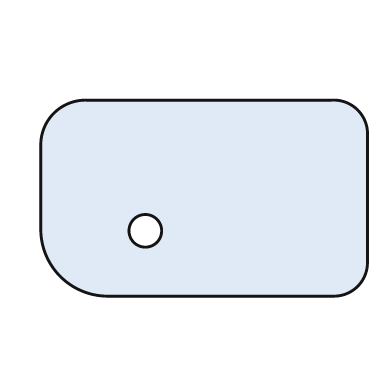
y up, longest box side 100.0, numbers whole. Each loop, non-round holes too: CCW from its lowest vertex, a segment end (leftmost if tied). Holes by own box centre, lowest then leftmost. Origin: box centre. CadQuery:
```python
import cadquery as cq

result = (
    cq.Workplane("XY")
    .moveTo(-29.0, -30.0)
    .lineTo(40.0, -30.0)
    .threePointArc((47.0, -27.0), (50.0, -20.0))
    .lineTo(50.0, 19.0)
    .threePointArc((47.0, 27.0), (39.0, 30.0))
    .lineTo(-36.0, 30.0)
    .threePointArc((-46.0, 26.0), (-50.0, 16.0))
    .lineTo(-50.0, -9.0)
    .threePointArc((-44.0, -24.0), (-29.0, -30.0))
    .close()
    .moveTo(-18.0, -10.0)
    .circle(5.0)
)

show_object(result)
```